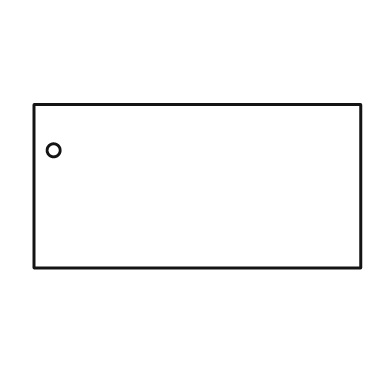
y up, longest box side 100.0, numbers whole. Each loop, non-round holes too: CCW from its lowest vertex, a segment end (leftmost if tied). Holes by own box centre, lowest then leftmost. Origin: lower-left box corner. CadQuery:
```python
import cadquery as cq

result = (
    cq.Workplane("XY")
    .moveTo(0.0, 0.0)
    .lineTo(100.0, 0.0)
    .lineTo(100.0, 50.0)
    .lineTo(0.0, 50.0)
    .close()
    .moveTo(6.0, 36.0)
    .circle(2.0)
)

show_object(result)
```